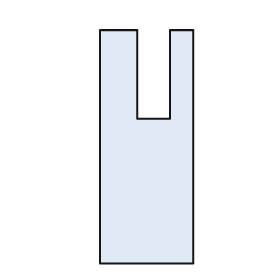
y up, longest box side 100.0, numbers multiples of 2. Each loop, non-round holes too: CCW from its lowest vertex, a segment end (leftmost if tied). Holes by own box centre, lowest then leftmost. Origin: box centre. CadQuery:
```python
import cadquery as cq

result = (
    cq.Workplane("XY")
    .moveTo(-20.0, -50.0)
    .lineTo(20.0, -50.0)
    .lineTo(20.0, 50.0)
    .lineTo(10.0, 50.0)
    .lineTo(10.0, 12.0)
    .lineTo(-4.0, 12.0)
    .lineTo(-4.0, 50.0)
    .lineTo(-20.0, 50.0)
    .close()
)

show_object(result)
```